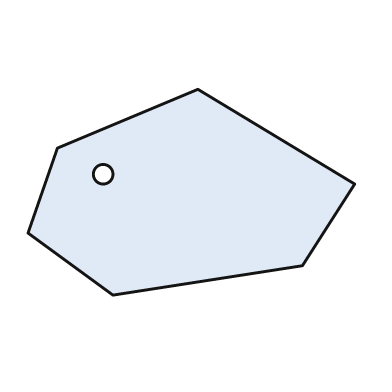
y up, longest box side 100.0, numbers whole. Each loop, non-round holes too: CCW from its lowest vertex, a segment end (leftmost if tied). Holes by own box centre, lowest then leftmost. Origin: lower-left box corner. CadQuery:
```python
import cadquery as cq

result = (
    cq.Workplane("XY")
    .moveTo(26.0, 0.0)
    .lineTo(84.0, 9.0)
    .lineTo(100.0, 34.0)
    .lineTo(52.0, 63.0)
    .lineTo(9.0, 45.0)
    .lineTo(0.0, 19.0)
    .close()
    .moveTo(23.0, 37.0)
    .circle(3.0)
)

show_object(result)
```